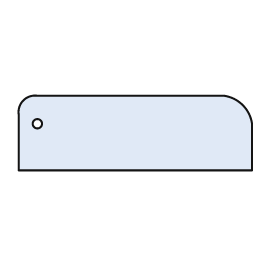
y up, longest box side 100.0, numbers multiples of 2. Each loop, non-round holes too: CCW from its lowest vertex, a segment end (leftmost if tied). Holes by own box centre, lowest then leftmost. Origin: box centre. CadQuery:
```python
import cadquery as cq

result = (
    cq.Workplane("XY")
    .moveTo(-50.0, -16.0)
    .lineTo(50.0, -16.0)
    .lineTo(50.0, 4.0)
    .threePointArc((46.0, 12.0), (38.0, 16.0))
    .lineTo(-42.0, 16.0)
    .threePointArc((-48.0, 14.0), (-50.0, 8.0))
    .close()
    .moveTo(-42.0, 4.0)
    .circle(2.0)
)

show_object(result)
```